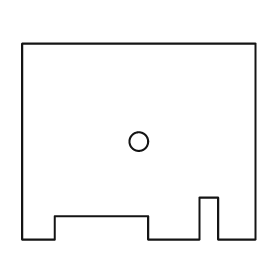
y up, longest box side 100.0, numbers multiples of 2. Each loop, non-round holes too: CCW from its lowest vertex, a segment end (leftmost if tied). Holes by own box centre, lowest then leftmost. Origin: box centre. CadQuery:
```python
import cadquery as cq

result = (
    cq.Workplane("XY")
    .moveTo(-50.0, -42.0)
    .lineTo(-36.0, -42.0)
    .lineTo(-36.0, -32.0)
    .lineTo(4.0, -32.0)
    .lineTo(4.0, -42.0)
    .lineTo(26.0, -42.0)
    .lineTo(26.0, -24.0)
    .lineTo(34.0, -24.0)
    .lineTo(34.0, -42.0)
    .lineTo(50.0, -42.0)
    .lineTo(50.0, 42.0)
    .lineTo(-50.0, 42.0)
    .close()
    .moveTo(0.0, 0.0)
    .circle(4.0)
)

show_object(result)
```